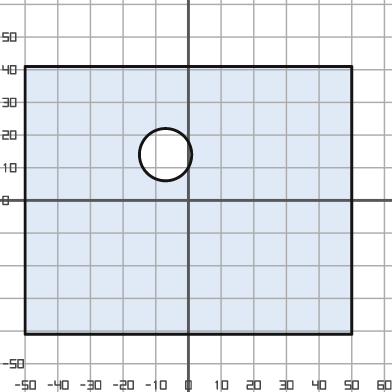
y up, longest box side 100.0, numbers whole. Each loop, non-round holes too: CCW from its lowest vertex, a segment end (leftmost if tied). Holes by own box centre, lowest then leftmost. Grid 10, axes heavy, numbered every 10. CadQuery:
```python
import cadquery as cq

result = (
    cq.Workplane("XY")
    .moveTo(-50.0, -41.0)
    .lineTo(50.0, -41.0)
    .lineTo(50.0, 41.0)
    .lineTo(-50.0, 41.0)
    .close()
    .moveTo(-7.0, 14.0)
    .circle(8.0)
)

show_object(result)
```